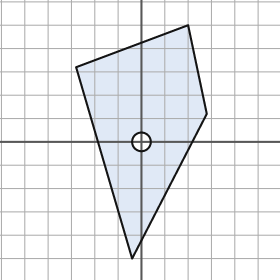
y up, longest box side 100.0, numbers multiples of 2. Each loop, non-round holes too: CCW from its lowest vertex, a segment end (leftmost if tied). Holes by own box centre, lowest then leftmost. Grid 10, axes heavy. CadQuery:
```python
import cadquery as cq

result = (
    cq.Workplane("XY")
    .moveTo(-4.0, -50.0)
    .lineTo(28.0, 12.0)
    .lineTo(20.0, 50.0)
    .lineTo(-28.0, 32.0)
    .close()
    .moveTo(0.0, 0.0)
    .circle(4.0)
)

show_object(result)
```